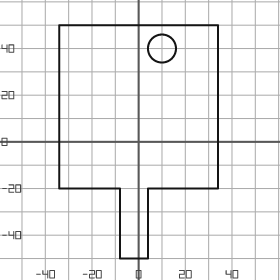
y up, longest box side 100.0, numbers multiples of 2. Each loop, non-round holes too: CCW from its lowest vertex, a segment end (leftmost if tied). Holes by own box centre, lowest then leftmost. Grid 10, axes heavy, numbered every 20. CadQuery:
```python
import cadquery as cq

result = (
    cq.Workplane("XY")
    .moveTo(-8.0, -50.0)
    .lineTo(4.0, -50.0)
    .lineTo(4.0, -20.0)
    .lineTo(34.0, -20.0)
    .lineTo(34.0, 50.0)
    .lineTo(-34.0, 50.0)
    .lineTo(-34.0, -20.0)
    .lineTo(-8.0, -20.0)
    .close()
    .moveTo(10.0, 40.0)
    .circle(6.0)
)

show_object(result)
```